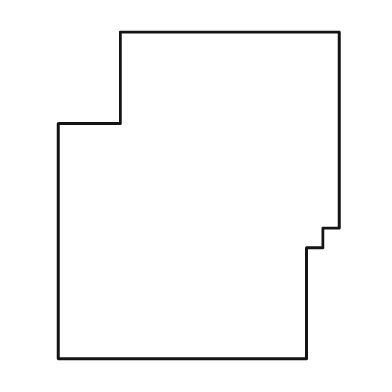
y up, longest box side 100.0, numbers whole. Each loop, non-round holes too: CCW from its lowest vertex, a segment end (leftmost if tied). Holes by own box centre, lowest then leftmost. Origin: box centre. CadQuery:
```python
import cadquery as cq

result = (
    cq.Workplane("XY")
    .moveTo(-43.0, -50.0)
    .lineTo(33.0, -50.0)
    .lineTo(33.0, -16.0)
    .lineTo(38.0, -16.0)
    .lineTo(38.0, -10.0)
    .lineTo(43.0, -10.0)
    .lineTo(43.0, 50.0)
    .lineTo(-24.0, 50.0)
    .lineTo(-24.0, 22.0)
    .lineTo(-43.0, 22.0)
    .close()
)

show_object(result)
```